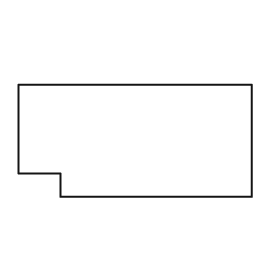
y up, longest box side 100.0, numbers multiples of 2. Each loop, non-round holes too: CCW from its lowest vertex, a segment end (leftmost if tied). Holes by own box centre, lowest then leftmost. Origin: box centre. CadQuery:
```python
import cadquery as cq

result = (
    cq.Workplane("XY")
    .moveTo(-32.0, -24.0)
    .lineTo(50.0, -24.0)
    .lineTo(50.0, 24.0)
    .lineTo(-50.0, 24.0)
    .lineTo(-50.0, -14.0)
    .lineTo(-32.0, -14.0)
    .close()
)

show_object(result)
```